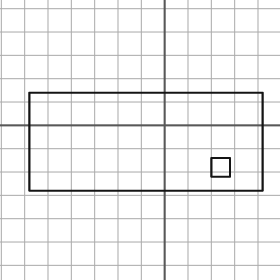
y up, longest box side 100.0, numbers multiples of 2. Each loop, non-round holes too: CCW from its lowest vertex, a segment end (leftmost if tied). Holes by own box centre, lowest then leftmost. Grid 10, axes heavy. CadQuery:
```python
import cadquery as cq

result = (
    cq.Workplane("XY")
    .moveTo(-58.0, -28.0)
    .lineTo(42.0, -28.0)
    .lineTo(42.0, 14.0)
    .lineTo(-58.0, 14.0)
    .close()
    .moveTo(20.0, -22.0)
    .lineTo(28.0, -22.0)
    .lineTo(28.0, -14.0)
    .lineTo(20.0, -14.0)
    .close()
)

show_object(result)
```